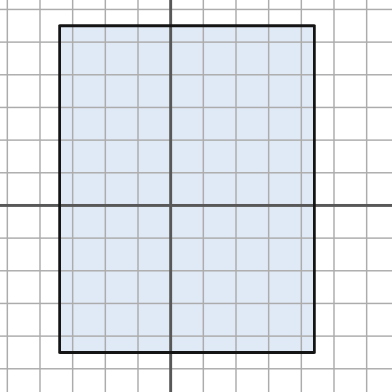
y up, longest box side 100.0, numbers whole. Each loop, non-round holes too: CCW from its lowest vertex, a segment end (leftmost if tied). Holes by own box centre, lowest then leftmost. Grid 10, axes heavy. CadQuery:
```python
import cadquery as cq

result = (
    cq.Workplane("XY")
    .moveTo(-34.0, -45.0)
    .lineTo(44.0, -45.0)
    .lineTo(44.0, 55.0)
    .lineTo(-34.0, 55.0)
    .close()
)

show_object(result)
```